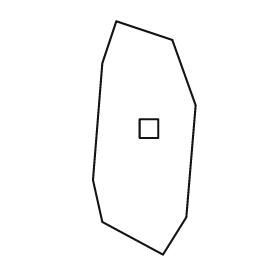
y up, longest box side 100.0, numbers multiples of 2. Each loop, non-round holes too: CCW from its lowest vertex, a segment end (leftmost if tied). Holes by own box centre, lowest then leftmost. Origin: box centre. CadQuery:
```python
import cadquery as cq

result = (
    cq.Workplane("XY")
    .moveTo(8.0, -50.0)
    .lineTo(18.0, -34.0)
    .lineTo(22.0, 14.0)
    .lineTo(12.0, 42.0)
    .lineTo(-12.0, 50.0)
    .lineTo(-18.0, 32.0)
    .lineTo(-22.0, -18.0)
    .lineTo(-18.0, -36.0)
    .close()
    .moveTo(-2.0, 0.0)
    .lineTo(6.0, 0.0)
    .lineTo(6.0, 8.0)
    .lineTo(-2.0, 8.0)
    .close()
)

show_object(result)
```